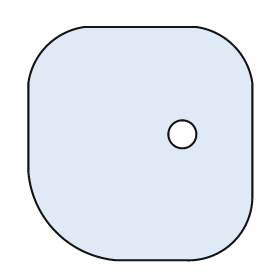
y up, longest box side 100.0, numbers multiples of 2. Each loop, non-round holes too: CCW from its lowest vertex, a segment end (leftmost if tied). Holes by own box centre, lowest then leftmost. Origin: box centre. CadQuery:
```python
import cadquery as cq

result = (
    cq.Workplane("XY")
    .moveTo(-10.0, -50.0)
    .lineTo(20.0, -50.0)
    .threePointArc((40.0, -42.0), (48.0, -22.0))
    .lineTo(48.0, 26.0)
    .threePointArc((40.0, 42.0), (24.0, 50.0))
    .lineTo(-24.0, 50.0)
    .threePointArc((-40.0, 42.0), (-48.0, 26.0))
    .lineTo(-48.0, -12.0)
    .threePointArc((-36.0, -38.0), (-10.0, -50.0))
    .close()
    .moveTo(18.0, 4.0)
    .circle(6.0)
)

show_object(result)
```